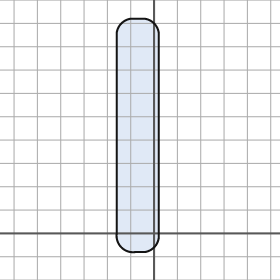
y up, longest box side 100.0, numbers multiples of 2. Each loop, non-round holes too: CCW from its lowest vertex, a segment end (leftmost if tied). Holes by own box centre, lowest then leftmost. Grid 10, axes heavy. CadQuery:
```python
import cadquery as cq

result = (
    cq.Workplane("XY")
    .moveTo(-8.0, -8.0)
    .lineTo(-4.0, -8.0)
    .threePointArc((0.0, -6.0), (2.0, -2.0))
    .lineTo(2.0, 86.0)
    .threePointArc((0.0, 90.0), (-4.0, 92.0))
    .lineTo(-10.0, 92.0)
    .threePointArc((-14.0, 90.0), (-16.0, 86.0))
    .lineTo(-16.0, 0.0)
    .threePointArc((-14.0, -6.0), (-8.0, -8.0))
    .close()
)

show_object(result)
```